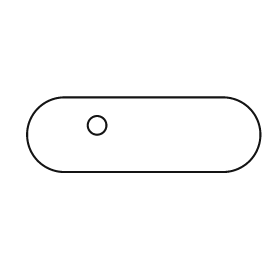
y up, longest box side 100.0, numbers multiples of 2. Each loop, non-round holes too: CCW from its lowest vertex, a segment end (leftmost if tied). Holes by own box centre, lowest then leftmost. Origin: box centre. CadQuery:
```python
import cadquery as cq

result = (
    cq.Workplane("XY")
    .moveTo(-34.0, -16.0)
    .lineTo(34.0, -16.0)
    .threePointArc((50.0, 0.0), (34.0, 16.0))
    .lineTo(-34.0, 16.0)
    .threePointArc((-50.0, 0.0), (-34.0, -16.0))
    .close()
    .moveTo(-20.0, 4.0)
    .circle(4.0)
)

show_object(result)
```